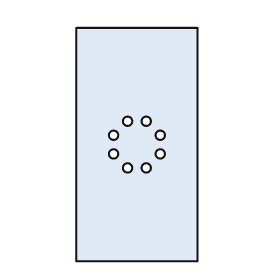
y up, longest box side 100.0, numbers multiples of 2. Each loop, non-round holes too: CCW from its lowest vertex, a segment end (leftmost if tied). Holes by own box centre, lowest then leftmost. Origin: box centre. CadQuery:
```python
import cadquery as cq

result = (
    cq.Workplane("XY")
    .moveTo(-26.0, -50.0)
    .lineTo(26.0, -50.0)
    .lineTo(26.0, 50.0)
    .lineTo(-26.0, 50.0)
    .close()
    .moveTo(-4.0, -10.0)
    .circle(2.0)
    .moveTo(4.0, -10.0)
    .circle(2.0)
    .moveTo(-10.0, -4.0)
    .circle(2.0)
    .moveTo(10.0, -4.0)
    .circle(2.0)
    .moveTo(-10.0, 4.0)
    .circle(2.0)
    .moveTo(10.0, 4.0)
    .circle(2.0)
    .moveTo(-4.0, 10.0)
    .circle(2.0)
    .moveTo(4.0, 10.0)
    .circle(2.0)
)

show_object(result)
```